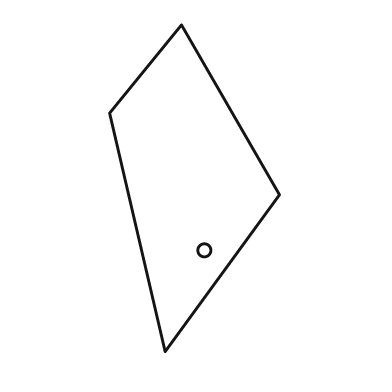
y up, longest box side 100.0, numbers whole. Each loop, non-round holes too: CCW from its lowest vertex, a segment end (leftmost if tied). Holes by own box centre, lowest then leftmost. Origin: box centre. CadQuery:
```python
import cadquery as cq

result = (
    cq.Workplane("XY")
    .moveTo(-9.0, -50.0)
    .lineTo(26.0, -2.0)
    .lineTo(-4.0, 50.0)
    .lineTo(-26.0, 23.0)
    .close()
    .moveTo(3.0, -19.0)
    .circle(2.0)
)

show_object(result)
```